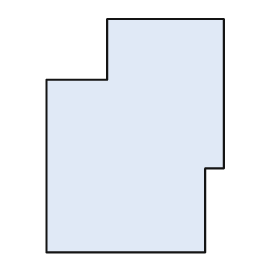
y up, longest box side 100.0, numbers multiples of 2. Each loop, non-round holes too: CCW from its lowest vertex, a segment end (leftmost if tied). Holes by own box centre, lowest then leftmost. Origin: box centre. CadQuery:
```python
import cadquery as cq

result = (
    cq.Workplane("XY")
    .moveTo(-38.0, -50.0)
    .lineTo(30.0, -50.0)
    .lineTo(30.0, -14.0)
    .lineTo(38.0, -14.0)
    .lineTo(38.0, 50.0)
    .lineTo(-12.0, 50.0)
    .lineTo(-12.0, 24.0)
    .lineTo(-38.0, 24.0)
    .close()
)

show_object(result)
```